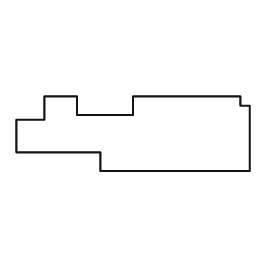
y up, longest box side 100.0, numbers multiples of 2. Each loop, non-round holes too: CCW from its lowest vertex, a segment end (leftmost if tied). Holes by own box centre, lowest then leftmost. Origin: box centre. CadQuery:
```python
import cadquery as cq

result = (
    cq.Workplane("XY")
    .moveTo(-14.0, -16.0)
    .lineTo(50.0, -16.0)
    .lineTo(50.0, 12.0)
    .lineTo(46.0, 12.0)
    .lineTo(46.0, 16.0)
    .lineTo(0.0, 16.0)
    .lineTo(0.0, 8.0)
    .lineTo(-24.0, 8.0)
    .lineTo(-24.0, 16.0)
    .lineTo(-38.0, 16.0)
    .lineTo(-38.0, 6.0)
    .lineTo(-50.0, 6.0)
    .lineTo(-50.0, -8.0)
    .lineTo(-14.0, -8.0)
    .close()
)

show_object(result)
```